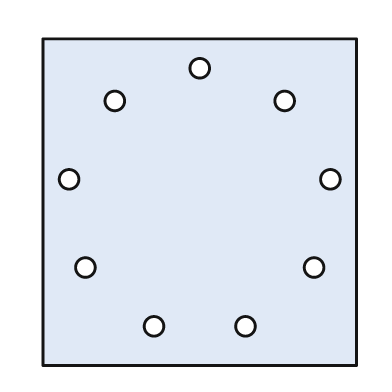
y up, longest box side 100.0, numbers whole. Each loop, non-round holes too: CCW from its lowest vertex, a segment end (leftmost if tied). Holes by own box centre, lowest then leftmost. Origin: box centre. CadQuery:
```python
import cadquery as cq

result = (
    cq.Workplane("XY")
    .moveTo(-48.0, -50.0)
    .lineTo(48.0, -50.0)
    .lineTo(48.0, 50.0)
    .lineTo(-48.0, 50.0)
    .close()
    .moveTo(-14.0, -38.0)
    .circle(3.0)
    .moveTo(14.0, -38.0)
    .circle(3.0)
    .moveTo(-35.0, -20.0)
    .circle(3.0)
    .moveTo(35.0, -20.0)
    .circle(3.0)
    .moveTo(-40.0, 7.0)
    .circle(3.0)
    .moveTo(40.0, 7.0)
    .circle(3.0)
    .moveTo(-26.0, 31.0)
    .circle(3.0)
    .moveTo(26.0, 31.0)
    .circle(3.0)
    .moveTo(0.0, 41.0)
    .circle(3.0)
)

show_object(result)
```